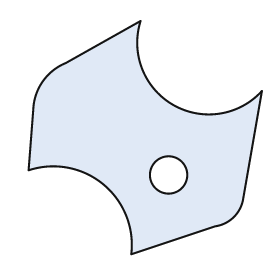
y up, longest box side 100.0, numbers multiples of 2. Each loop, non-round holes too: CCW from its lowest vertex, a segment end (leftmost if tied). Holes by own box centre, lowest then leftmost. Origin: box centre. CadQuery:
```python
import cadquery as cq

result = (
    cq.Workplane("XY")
    .moveTo(-6.0, -50.0)
    .lineTo(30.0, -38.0)
    .threePointArc((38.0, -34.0), (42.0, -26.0))
    .lineTo(50.0, 20.0)
    .threePointArc((12.0, 14.0), (-2.0, 50.0))
    .lineTo(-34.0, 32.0)
    .threePointArc((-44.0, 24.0), (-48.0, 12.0))
    .lineTo(-50.0, -14.0)
    .threePointArc((-18.0, -20.0), (-6.0, -50.0))
    .close()
    .moveTo(10.0, -16.0)
    .circle(8.0)
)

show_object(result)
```